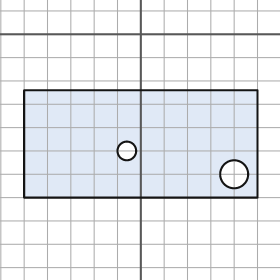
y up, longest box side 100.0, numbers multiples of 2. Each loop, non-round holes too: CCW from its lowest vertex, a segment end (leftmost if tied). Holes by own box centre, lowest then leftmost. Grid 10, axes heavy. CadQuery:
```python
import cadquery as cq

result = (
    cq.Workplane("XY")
    .moveTo(-50.0, -70.0)
    .lineTo(50.0, -70.0)
    .lineTo(50.0, -24.0)
    .lineTo(-50.0, -24.0)
    .close()
    .moveTo(40.0, -60.0)
    .circle(6.0)
    .moveTo(-6.0, -50.0)
    .circle(4.0)
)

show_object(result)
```